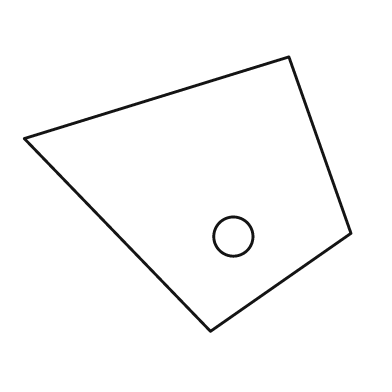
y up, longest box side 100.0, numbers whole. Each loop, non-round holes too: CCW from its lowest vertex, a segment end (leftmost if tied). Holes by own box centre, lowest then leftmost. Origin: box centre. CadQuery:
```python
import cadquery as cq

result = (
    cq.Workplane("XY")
    .moveTo(7.0, -42.0)
    .lineTo(50.0, -12.0)
    .lineTo(31.0, 42.0)
    .lineTo(-50.0, 17.0)
    .close()
    .moveTo(14.0, -13.0)
    .circle(6.0)
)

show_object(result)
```